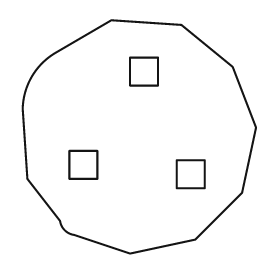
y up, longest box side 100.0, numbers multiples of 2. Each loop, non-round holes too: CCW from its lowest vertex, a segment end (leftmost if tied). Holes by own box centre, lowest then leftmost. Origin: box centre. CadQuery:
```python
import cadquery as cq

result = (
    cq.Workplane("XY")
    .moveTo(-4.0, -50.0)
    .lineTo(24.0, -44.0)
    .lineTo(44.0, -24.0)
    .lineTo(50.0, 4.0)
    .lineTo(40.0, 30.0)
    .lineTo(18.0, 48.0)
    .lineTo(-12.0, 50.0)
    .lineTo(-36.0, 36.0)
    .threePointArc((-46.0, 26.0), (-50.0, 12.0))
    .lineTo(-48.0, -18.0)
    .lineTo(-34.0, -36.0)
    .threePointArc((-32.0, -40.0), (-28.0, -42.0))
    .close()
    .moveTo(16.0, -22.0)
    .lineTo(28.0, -22.0)
    .lineTo(28.0, -10.0)
    .lineTo(16.0, -10.0)
    .close()
    .moveTo(-30.0, -18.0)
    .lineTo(-18.0, -18.0)
    .lineTo(-18.0, -6.0)
    .lineTo(-30.0, -6.0)
    .close()
    .moveTo(-4.0, 22.0)
    .lineTo(8.0, 22.0)
    .lineTo(8.0, 34.0)
    .lineTo(-4.0, 34.0)
    .close()
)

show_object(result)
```